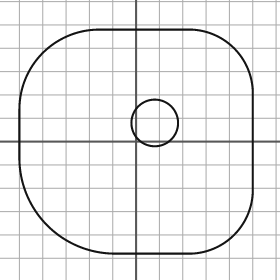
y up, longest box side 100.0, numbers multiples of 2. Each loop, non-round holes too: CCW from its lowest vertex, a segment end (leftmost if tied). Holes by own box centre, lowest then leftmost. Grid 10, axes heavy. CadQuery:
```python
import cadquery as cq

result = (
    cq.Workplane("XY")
    .moveTo(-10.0, -48.0)
    .lineTo(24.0, -48.0)
    .threePointArc((42.0, -40.0), (50.0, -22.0))
    .lineTo(50.0, 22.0)
    .threePointArc((42.0, 40.0), (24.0, 48.0))
    .lineTo(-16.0, 48.0)
    .threePointArc((-40.0, 38.0), (-50.0, 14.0))
    .lineTo(-50.0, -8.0)
    .threePointArc((-38.0, -36.0), (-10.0, -48.0))
    .close()
    .moveTo(8.0, 8.0)
    .circle(10.0)
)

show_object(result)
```